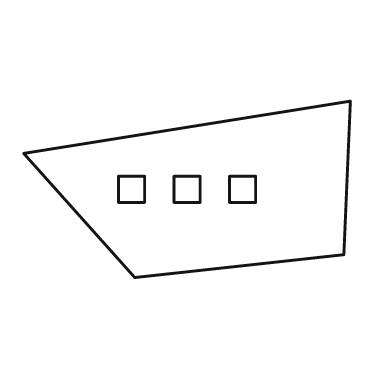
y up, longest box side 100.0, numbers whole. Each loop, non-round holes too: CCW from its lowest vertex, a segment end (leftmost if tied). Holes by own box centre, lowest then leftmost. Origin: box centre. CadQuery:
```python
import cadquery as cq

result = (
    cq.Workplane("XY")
    .moveTo(-16.0, -27.0)
    .lineTo(48.0, -20.0)
    .lineTo(50.0, 27.0)
    .lineTo(-50.0, 11.0)
    .close()
    .moveTo(-21.0, -4.0)
    .lineTo(-13.0, -4.0)
    .lineTo(-13.0, 4.0)
    .lineTo(-21.0, 4.0)
    .close()
    .moveTo(-4.0, -4.0)
    .lineTo(4.0, -4.0)
    .lineTo(4.0, 4.0)
    .lineTo(-4.0, 4.0)
    .close()
    .moveTo(13.0, -4.0)
    .lineTo(21.0, -4.0)
    .lineTo(21.0, 4.0)
    .lineTo(13.0, 4.0)
    .close()
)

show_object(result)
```